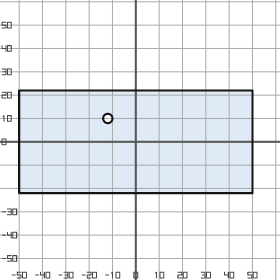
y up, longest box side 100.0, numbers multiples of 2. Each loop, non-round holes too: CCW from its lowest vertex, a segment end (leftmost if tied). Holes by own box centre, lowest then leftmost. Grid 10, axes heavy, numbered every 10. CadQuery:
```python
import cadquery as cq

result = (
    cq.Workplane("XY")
    .moveTo(-50.0, -22.0)
    .lineTo(50.0, -22.0)
    .lineTo(50.0, 22.0)
    .lineTo(-50.0, 22.0)
    .close()
    .moveTo(-12.0, 10.0)
    .circle(2.0)
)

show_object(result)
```